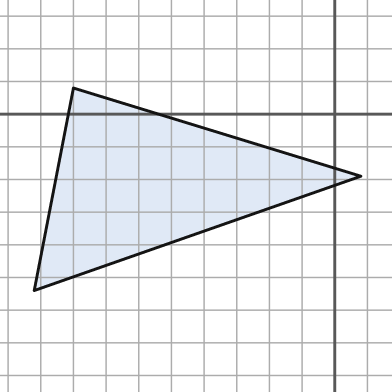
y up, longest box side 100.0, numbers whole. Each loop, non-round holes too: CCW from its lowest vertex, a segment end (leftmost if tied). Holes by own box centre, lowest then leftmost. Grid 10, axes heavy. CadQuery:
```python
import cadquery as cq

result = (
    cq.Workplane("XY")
    .moveTo(-92.0, -54.0)
    .lineTo(8.0, -19.0)
    .lineTo(-80.0, 8.0)
    .close()
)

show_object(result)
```